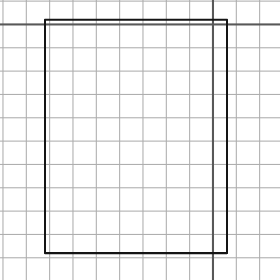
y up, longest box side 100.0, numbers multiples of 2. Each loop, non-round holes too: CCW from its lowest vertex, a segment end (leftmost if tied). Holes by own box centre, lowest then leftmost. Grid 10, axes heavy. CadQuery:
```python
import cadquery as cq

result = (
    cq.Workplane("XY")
    .moveTo(-72.0, -98.0)
    .lineTo(6.0, -98.0)
    .lineTo(6.0, 2.0)
    .lineTo(-72.0, 2.0)
    .close()
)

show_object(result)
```